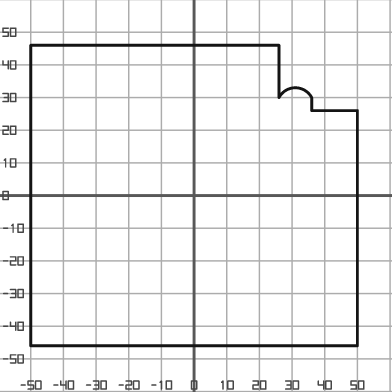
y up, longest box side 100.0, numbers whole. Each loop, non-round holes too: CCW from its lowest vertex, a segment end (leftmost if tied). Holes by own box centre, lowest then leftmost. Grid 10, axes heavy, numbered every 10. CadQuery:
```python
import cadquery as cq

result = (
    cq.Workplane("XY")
    .moveTo(-50.0, -46.0)
    .lineTo(50.0, -46.0)
    .lineTo(50.0, 26.0)
    .lineTo(36.0, 26.0)
    .lineTo(36.0, 30.0)
    .threePointArc((31.0, 33.0), (26.0, 30.0))
    .lineTo(26.0, 46.0)
    .lineTo(-50.0, 46.0)
    .close()
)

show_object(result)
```